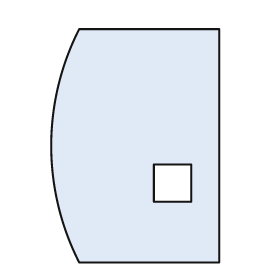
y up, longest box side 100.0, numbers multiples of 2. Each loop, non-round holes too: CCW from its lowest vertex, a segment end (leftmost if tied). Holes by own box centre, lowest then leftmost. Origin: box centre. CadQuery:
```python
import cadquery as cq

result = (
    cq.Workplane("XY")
    .moveTo(-24.0, -50.0)
    .lineTo(36.0, -50.0)
    .lineTo(36.0, 50.0)
    .lineTo(-24.0, 50.0)
    .threePointArc((-36.0, 0.0), (-24.0, -50.0))
    .close()
    .moveTo(8.0, -24.0)
    .lineTo(24.0, -24.0)
    .lineTo(24.0, -8.0)
    .lineTo(8.0, -8.0)
    .close()
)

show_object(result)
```